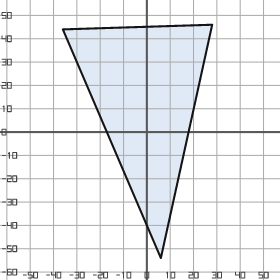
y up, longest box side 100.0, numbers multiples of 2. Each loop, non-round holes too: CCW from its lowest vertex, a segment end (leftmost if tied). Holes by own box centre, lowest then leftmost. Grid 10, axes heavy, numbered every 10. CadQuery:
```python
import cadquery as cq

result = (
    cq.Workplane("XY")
    .moveTo(6.0, -54.0)
    .lineTo(28.0, 46.0)
    .lineTo(-36.0, 44.0)
    .close()
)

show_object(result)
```